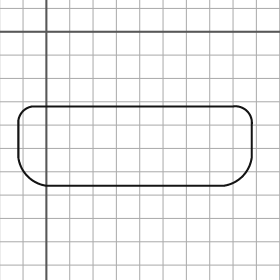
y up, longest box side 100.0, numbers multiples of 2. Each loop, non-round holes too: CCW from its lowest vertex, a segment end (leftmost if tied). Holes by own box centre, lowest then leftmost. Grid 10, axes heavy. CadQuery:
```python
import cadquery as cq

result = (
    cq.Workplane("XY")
    .moveTo(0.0, -66.0)
    .lineTo(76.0, -66.0)
    .threePointArc((84.0, -62.0), (88.0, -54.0))
    .lineTo(88.0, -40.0)
    .threePointArc((86.0, -34.0), (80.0, -32.0))
    .lineTo(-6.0, -32.0)
    .threePointArc((-10.0, -34.0), (-12.0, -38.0))
    .lineTo(-12.0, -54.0)
    .threePointArc((-8.0, -62.0), (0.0, -66.0))
    .close()
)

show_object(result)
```